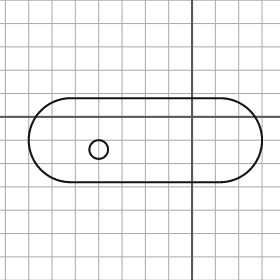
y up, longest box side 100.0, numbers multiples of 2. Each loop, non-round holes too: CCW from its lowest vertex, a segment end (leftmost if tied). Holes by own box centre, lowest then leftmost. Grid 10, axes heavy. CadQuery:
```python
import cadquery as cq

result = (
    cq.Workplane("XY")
    .moveTo(-52.0, -28.0)
    .lineTo(12.0, -28.0)
    .threePointArc((30.0, -10.0), (12.0, 8.0))
    .lineTo(-52.0, 8.0)
    .threePointArc((-70.0, -10.0), (-52.0, -28.0))
    .close()
    .moveTo(-40.0, -14.0)
    .circle(4.0)
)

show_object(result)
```